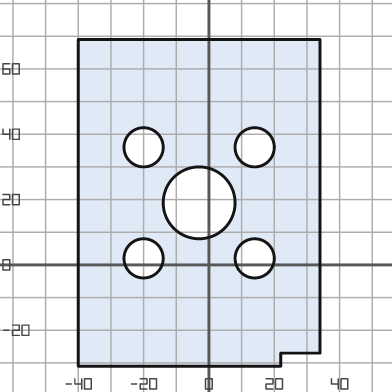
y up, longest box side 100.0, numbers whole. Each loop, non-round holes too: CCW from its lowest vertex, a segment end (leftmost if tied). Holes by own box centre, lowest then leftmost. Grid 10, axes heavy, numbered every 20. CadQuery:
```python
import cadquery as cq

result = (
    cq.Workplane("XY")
    .moveTo(-40.0, -31.0)
    .lineTo(22.0, -31.0)
    .lineTo(22.0, -27.0)
    .lineTo(34.0, -27.0)
    .lineTo(34.0, 69.0)
    .lineTo(-40.0, 69.0)
    .close()
    .moveTo(-20.0, 2.0)
    .circle(6.0)
    .moveTo(14.0, 2.0)
    .circle(6.0)
    .moveTo(-3.0, 19.0)
    .circle(11.0)
    .moveTo(-20.0, 36.0)
    .circle(6.0)
    .moveTo(14.0, 36.0)
    .circle(6.0)
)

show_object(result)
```